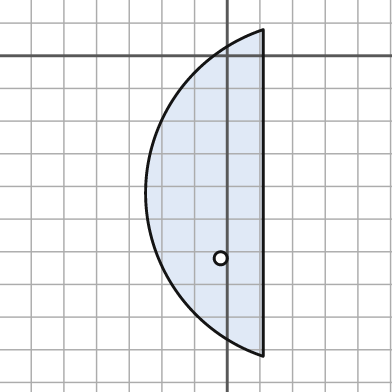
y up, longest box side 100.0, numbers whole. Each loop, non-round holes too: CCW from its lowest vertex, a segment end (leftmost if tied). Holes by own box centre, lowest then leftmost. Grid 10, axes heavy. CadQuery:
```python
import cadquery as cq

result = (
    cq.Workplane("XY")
    .moveTo(11.0, -92.0)
    .lineTo(11.0, 8.0)
    .threePointArc((-25.0, -42.0), (11.0, -92.0))
    .close()
    .moveTo(-2.0, -62.0)
    .circle(2.0)
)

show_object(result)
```